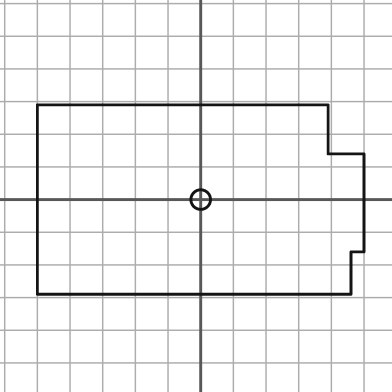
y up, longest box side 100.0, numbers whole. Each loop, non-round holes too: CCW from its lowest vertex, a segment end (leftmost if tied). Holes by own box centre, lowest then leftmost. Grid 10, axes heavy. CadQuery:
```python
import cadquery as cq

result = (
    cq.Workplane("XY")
    .moveTo(-50.0, -29.0)
    .lineTo(46.0, -29.0)
    .lineTo(46.0, -16.0)
    .lineTo(50.0, -16.0)
    .lineTo(50.0, 14.0)
    .lineTo(39.0, 14.0)
    .lineTo(39.0, 29.0)
    .lineTo(-50.0, 29.0)
    .close()
    .moveTo(0.0, 0.0)
    .circle(3.0)
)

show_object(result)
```